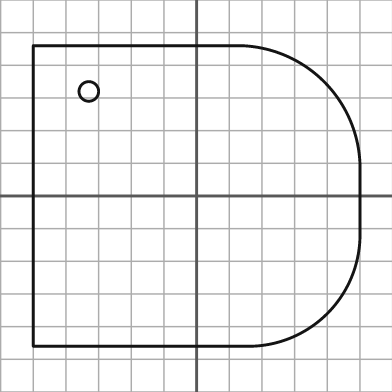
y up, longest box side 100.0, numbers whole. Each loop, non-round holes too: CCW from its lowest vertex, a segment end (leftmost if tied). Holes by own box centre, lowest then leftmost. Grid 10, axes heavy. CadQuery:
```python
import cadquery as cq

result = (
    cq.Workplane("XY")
    .moveTo(-50.0, -46.0)
    .lineTo(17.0, -46.0)
    .threePointArc((40.0, -36.0), (50.0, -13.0))
    .lineTo(50.0, 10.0)
    .threePointArc((39.0, 35.0), (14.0, 46.0))
    .lineTo(-50.0, 46.0)
    .close()
    .moveTo(-33.0, 32.0)
    .circle(3.0)
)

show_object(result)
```